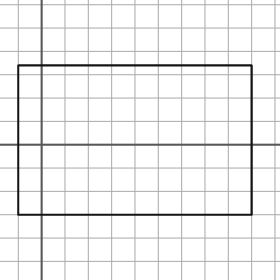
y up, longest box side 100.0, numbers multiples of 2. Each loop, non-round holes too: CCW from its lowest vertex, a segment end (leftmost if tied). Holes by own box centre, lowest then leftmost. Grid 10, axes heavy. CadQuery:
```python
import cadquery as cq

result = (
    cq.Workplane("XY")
    .moveTo(-10.0, -30.0)
    .lineTo(90.0, -30.0)
    .lineTo(90.0, 34.0)
    .lineTo(-10.0, 34.0)
    .close()
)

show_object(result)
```